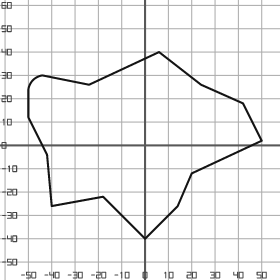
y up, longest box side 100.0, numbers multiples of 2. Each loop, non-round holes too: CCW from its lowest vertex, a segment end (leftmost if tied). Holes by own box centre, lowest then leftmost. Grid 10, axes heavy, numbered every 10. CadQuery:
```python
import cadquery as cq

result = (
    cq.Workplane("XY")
    .moveTo(0.0, -40.0)
    .lineTo(14.0, -26.0)
    .lineTo(20.0, -12.0)
    .lineTo(50.0, 2.0)
    .lineTo(42.0, 18.0)
    .lineTo(24.0, 26.0)
    .lineTo(6.0, 40.0)
    .lineTo(-24.0, 26.0)
    .lineTo(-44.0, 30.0)
    .threePointArc((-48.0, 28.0), (-50.0, 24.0))
    .lineTo(-50.0, 12.0)
    .lineTo(-42.0, -4.0)
    .lineTo(-40.0, -26.0)
    .lineTo(-18.0, -22.0)
    .close()
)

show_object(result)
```